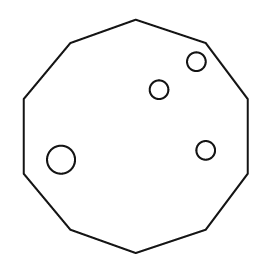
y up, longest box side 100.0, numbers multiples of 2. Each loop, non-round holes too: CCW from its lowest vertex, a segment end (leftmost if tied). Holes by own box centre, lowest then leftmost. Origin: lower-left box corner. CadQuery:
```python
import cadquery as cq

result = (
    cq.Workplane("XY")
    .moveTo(48.0, 0.0)
    .lineTo(78.0, 10.0)
    .lineTo(96.0, 34.0)
    .lineTo(96.0, 66.0)
    .lineTo(78.0, 90.0)
    .lineTo(48.0, 100.0)
    .lineTo(20.0, 90.0)
    .lineTo(0.0, 66.0)
    .lineTo(0.0, 34.0)
    .lineTo(20.0, 10.0)
    .close()
    .moveTo(16.0, 40.0)
    .circle(6.0)
    .moveTo(78.0, 44.0)
    .circle(4.0)
    .moveTo(58.0, 70.0)
    .circle(4.0)
    .moveTo(74.0, 82.0)
    .circle(4.0)
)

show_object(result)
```